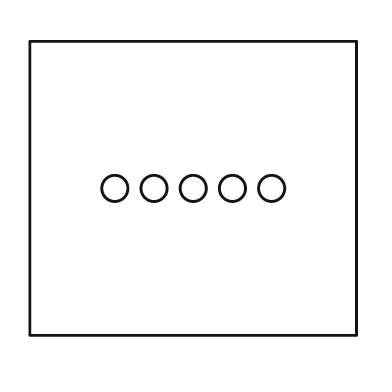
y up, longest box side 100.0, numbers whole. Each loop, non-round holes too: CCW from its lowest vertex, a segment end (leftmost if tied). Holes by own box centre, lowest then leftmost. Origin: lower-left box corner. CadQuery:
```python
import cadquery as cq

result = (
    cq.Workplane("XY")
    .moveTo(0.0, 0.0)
    .lineTo(100.0, 0.0)
    .lineTo(100.0, 90.0)
    .lineTo(0.0, 90.0)
    .close()
    .moveTo(26.0, 45.0)
    .circle(4.0)
    .moveTo(38.0, 45.0)
    .circle(4.0)
    .moveTo(50.0, 45.0)
    .circle(4.0)
    .moveTo(62.0, 45.0)
    .circle(4.0)
    .moveTo(74.0, 45.0)
    .circle(4.0)
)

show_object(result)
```